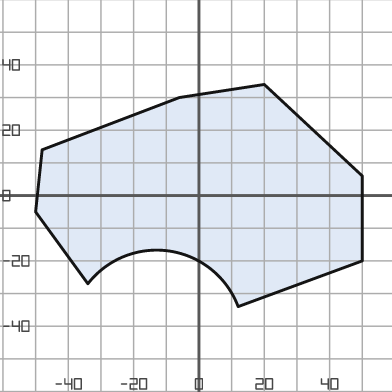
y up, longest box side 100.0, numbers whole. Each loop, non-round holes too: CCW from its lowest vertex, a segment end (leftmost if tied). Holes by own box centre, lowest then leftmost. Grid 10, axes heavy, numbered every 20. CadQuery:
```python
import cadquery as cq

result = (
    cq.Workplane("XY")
    .moveTo(12.0, -34.0)
    .lineTo(50.0, -20.0)
    .lineTo(50.0, 6.0)
    .lineTo(20.0, 34.0)
    .lineTo(-6.0, 30.0)
    .lineTo(-48.0, 14.0)
    .lineTo(-50.0, -5.0)
    .lineTo(-34.0, -27.0)
    .threePointArc((-9.0, -17.0), (12.0, -34.0))
    .close()
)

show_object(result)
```